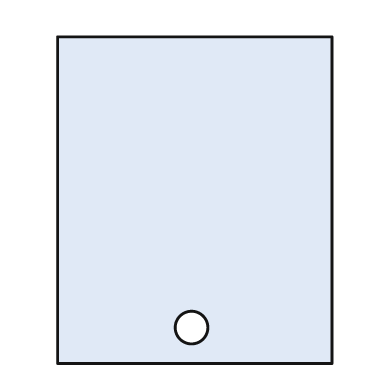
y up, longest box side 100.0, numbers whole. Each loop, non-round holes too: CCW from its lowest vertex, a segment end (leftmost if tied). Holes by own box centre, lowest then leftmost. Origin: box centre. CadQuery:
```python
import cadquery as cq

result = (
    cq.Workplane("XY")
    .moveTo(-42.0, -50.0)
    .lineTo(42.0, -50.0)
    .lineTo(42.0, 50.0)
    .lineTo(-42.0, 50.0)
    .close()
    .moveTo(-1.0, -39.0)
    .circle(5.0)
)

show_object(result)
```